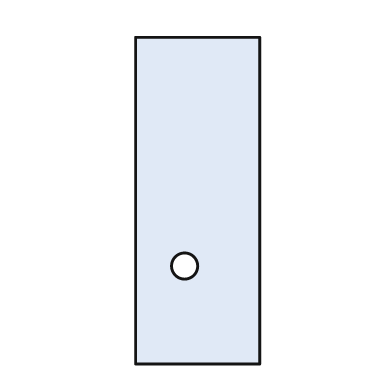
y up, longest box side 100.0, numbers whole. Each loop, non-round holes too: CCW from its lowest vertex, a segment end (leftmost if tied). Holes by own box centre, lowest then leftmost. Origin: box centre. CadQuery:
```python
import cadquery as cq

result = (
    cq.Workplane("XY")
    .moveTo(-19.0, -50.0)
    .lineTo(19.0, -50.0)
    .lineTo(19.0, 50.0)
    .lineTo(-19.0, 50.0)
    .close()
    .moveTo(-4.0, -20.0)
    .circle(4.0)
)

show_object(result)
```